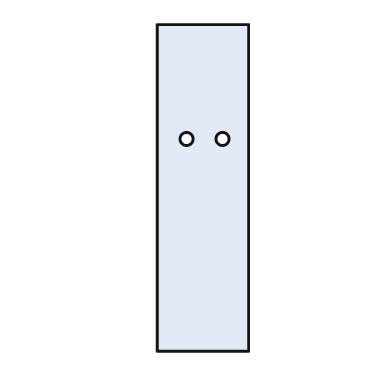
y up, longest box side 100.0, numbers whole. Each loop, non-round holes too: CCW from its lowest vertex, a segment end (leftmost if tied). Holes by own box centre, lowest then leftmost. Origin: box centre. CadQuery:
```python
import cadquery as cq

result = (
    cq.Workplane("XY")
    .moveTo(-14.0, -50.0)
    .lineTo(14.0, -50.0)
    .lineTo(14.0, 50.0)
    .lineTo(-14.0, 50.0)
    .close()
    .moveTo(-5.0, 15.0)
    .circle(2.0)
    .moveTo(6.0, 15.0)
    .circle(2.0)
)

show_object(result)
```